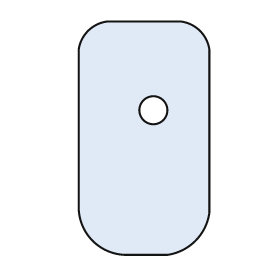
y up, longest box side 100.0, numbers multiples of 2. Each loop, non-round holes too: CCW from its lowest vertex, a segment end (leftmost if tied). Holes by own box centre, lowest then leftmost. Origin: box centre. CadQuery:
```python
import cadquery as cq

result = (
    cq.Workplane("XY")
    .moveTo(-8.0, -50.0)
    .lineTo(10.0, -50.0)
    .threePointArc((22.0, -44.0), (28.0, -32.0))
    .lineTo(28.0, 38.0)
    .threePointArc((24.0, 46.0), (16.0, 50.0))
    .lineTo(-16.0, 50.0)
    .threePointArc((-24.0, 46.0), (-28.0, 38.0))
    .lineTo(-28.0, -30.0)
    .threePointArc((-22.0, -44.0), (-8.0, -50.0))
    .close()
    .moveTo(4.0, 12.0)
    .circle(6.0)
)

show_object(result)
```